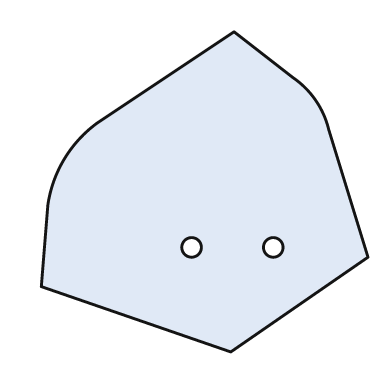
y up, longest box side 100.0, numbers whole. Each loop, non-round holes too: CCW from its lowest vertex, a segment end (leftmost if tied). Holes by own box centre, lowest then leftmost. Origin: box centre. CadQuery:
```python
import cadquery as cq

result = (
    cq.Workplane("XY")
    .moveTo(8.0, -49.0)
    .lineTo(50.0, -20.0)
    .lineTo(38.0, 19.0)
    .threePointArc((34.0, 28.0), (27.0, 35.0))
    .lineTo(9.0, 49.0)
    .lineTo(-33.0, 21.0)
    .threePointArc((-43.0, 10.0), (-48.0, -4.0))
    .lineTo(-50.0, -29.0)
    .close()
    .moveTo(-4.0, -17.0)
    .circle(3.0)
    .moveTo(21.0, -17.0)
    .circle(3.0)
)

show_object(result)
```